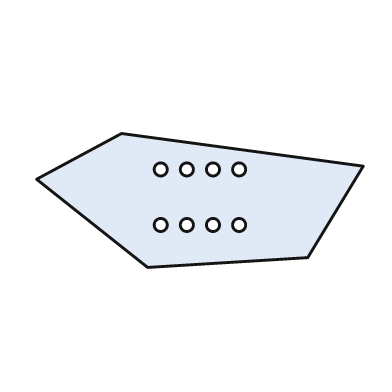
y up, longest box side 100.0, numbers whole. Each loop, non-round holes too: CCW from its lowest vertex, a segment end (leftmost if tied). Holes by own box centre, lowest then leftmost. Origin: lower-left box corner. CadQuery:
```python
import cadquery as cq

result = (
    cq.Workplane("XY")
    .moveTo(34.0, 0.0)
    .lineTo(83.0, 3.0)
    .lineTo(100.0, 31.0)
    .lineTo(26.0, 41.0)
    .lineTo(0.0, 27.0)
    .close()
    .moveTo(38.0, 13.0)
    .circle(2.0)
    .moveTo(46.0, 13.0)
    .circle(2.0)
    .moveTo(54.0, 13.0)
    .circle(2.0)
    .moveTo(62.0, 13.0)
    .circle(2.0)
    .moveTo(38.0, 30.0)
    .circle(2.0)
    .moveTo(46.0, 30.0)
    .circle(2.0)
    .moveTo(54.0, 30.0)
    .circle(2.0)
    .moveTo(62.0, 30.0)
    .circle(2.0)
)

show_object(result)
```